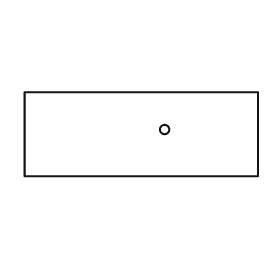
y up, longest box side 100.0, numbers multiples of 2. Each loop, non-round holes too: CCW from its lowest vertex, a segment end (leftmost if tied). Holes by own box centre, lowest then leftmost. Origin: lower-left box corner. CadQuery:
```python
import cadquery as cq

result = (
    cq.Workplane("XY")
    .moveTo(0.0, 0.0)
    .lineTo(100.0, 0.0)
    .lineTo(100.0, 36.0)
    .lineTo(0.0, 36.0)
    .close()
    .moveTo(60.0, 20.0)
    .circle(2.0)
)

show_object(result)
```